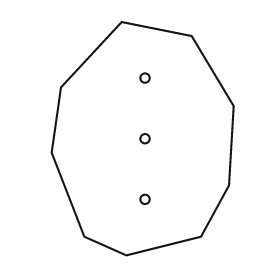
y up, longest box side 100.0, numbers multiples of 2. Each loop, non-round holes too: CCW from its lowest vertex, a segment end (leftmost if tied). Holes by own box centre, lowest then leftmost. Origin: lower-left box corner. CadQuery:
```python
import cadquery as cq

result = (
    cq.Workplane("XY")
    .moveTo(32.0, 0.0)
    .lineTo(64.0, 8.0)
    .lineTo(76.0, 30.0)
    .lineTo(78.0, 64.0)
    .lineTo(60.0, 94.0)
    .lineTo(30.0, 100.0)
    .lineTo(4.0, 72.0)
    .lineTo(0.0, 44.0)
    .lineTo(14.0, 8.0)
    .close()
    .moveTo(40.0, 24.0)
    .circle(2.0)
    .moveTo(40.0, 50.0)
    .circle(2.0)
    .moveTo(40.0, 76.0)
    .circle(2.0)
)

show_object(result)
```